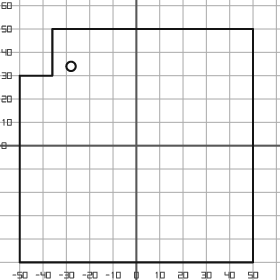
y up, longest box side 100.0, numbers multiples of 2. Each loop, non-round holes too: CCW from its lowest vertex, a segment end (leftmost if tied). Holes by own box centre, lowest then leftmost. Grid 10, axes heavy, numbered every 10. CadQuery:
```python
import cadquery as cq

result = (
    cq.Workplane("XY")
    .moveTo(-50.0, -50.0)
    .lineTo(50.0, -50.0)
    .lineTo(50.0, 50.0)
    .lineTo(-36.0, 50.0)
    .lineTo(-36.0, 30.0)
    .lineTo(-50.0, 30.0)
    .close()
    .moveTo(-28.0, 34.0)
    .circle(2.0)
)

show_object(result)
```